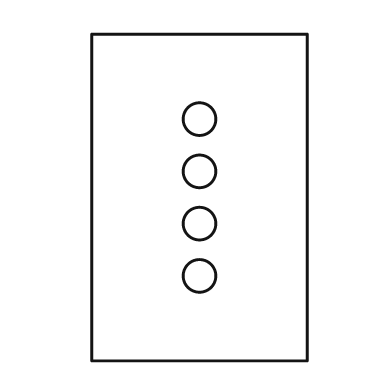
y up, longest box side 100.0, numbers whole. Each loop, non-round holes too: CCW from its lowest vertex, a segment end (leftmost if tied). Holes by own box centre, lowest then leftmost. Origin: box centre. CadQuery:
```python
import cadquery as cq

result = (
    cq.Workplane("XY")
    .moveTo(-33.0, -50.0)
    .lineTo(33.0, -50.0)
    .lineTo(33.0, 50.0)
    .lineTo(-33.0, 50.0)
    .close()
    .moveTo(0.0, -24.0)
    .circle(5.0)
    .moveTo(0.0, -8.0)
    .circle(5.0)
    .moveTo(0.0, 8.0)
    .circle(5.0)
    .moveTo(0.0, 24.0)
    .circle(5.0)
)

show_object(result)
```